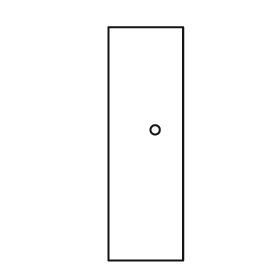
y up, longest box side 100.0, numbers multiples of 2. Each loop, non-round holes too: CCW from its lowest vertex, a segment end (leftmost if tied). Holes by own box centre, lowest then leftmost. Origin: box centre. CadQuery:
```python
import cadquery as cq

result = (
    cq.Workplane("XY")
    .moveTo(-16.0, -50.0)
    .lineTo(16.0, -50.0)
    .lineTo(16.0, 50.0)
    .lineTo(-16.0, 50.0)
    .close()
    .moveTo(4.0, 6.0)
    .circle(2.0)
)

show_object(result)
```